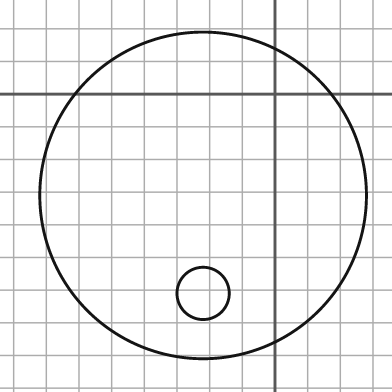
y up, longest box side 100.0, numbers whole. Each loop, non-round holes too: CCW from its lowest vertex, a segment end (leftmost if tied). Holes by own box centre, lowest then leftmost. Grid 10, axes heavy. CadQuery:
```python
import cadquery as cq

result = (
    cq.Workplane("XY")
    .moveTo(-22.0, -31.0)
    .circle(50.0)
    .moveTo(-22.0, -61.0)
    .circle(8.0)
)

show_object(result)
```